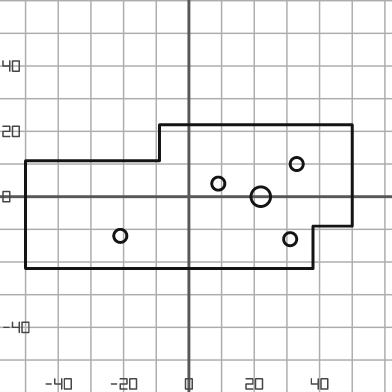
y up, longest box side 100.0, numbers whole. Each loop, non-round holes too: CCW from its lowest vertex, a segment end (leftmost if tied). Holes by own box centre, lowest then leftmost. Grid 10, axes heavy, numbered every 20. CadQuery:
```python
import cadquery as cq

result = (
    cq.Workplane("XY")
    .moveTo(-50.0, -22.0)
    .lineTo(38.0, -22.0)
    .lineTo(38.0, -9.0)
    .lineTo(50.0, -9.0)
    .lineTo(50.0, 22.0)
    .lineTo(-9.0, 22.0)
    .lineTo(-9.0, 11.0)
    .lineTo(-50.0, 11.0)
    .close()
    .moveTo(31.0, -13.0)
    .circle(2.0)
    .moveTo(-21.0, -12.0)
    .circle(2.0)
    .moveTo(22.0, 0.0)
    .circle(3.0)
    .moveTo(9.0, 4.0)
    .circle(2.0)
    .moveTo(33.0, 10.0)
    .circle(2.0)
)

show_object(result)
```